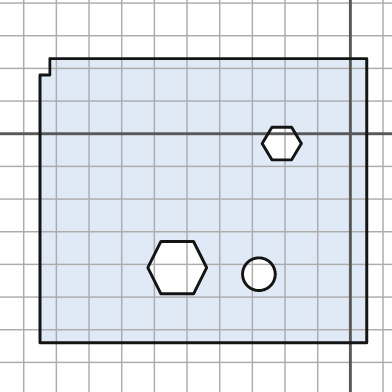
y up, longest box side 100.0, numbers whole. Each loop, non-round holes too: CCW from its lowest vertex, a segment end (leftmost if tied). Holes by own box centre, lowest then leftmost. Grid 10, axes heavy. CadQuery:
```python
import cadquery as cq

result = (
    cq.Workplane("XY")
    .moveTo(-95.0, -64.0)
    .lineTo(5.0, -64.0)
    .lineTo(5.0, 23.0)
    .lineTo(-92.0, 23.0)
    .lineTo(-92.0, 18.0)
    .lineTo(-95.0, 18.0)
    .close()
    .moveTo(-28.0, -43.0)
    .circle(5.0)
    .moveTo(-58.0, -49.0)
    .lineTo(-48.0, -49.0)
    .lineTo(-44.0, -41.0)
    .lineTo(-48.0, -33.0)
    .lineTo(-58.0, -33.0)
    .lineTo(-62.0, -41.0)
    .close()
    .moveTo(-24.0, -8.0)
    .lineTo(-18.0, -8.0)
    .lineTo(-15.0, -3.0)
    .lineTo(-18.0, 2.0)
    .lineTo(-24.0, 2.0)
    .lineTo(-27.0, -3.0)
    .close()
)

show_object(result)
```